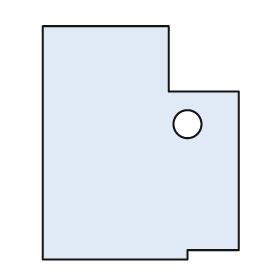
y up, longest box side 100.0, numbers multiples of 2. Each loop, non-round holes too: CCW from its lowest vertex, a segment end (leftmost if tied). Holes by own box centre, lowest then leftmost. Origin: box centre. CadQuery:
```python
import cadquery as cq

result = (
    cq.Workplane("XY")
    .moveTo(-42.0, -50.0)
    .lineTo(20.0, -50.0)
    .lineTo(20.0, -46.0)
    .lineTo(42.0, -46.0)
    .lineTo(42.0, 22.0)
    .lineTo(12.0, 22.0)
    .lineTo(12.0, 50.0)
    .lineTo(-42.0, 50.0)
    .close()
    .moveTo(20.0, 8.0)
    .circle(6.0)
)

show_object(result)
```